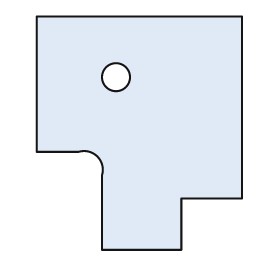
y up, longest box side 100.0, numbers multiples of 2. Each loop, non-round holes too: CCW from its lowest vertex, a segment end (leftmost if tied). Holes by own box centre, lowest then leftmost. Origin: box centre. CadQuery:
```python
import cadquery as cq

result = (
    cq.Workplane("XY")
    .moveTo(-16.0, -50.0)
    .lineTo(18.0, -50.0)
    .lineTo(18.0, -28.0)
    .lineTo(44.0, -28.0)
    .lineTo(44.0, 50.0)
    .lineTo(-44.0, 50.0)
    .lineTo(-44.0, -8.0)
    .lineTo(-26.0, -8.0)
    .threePointArc((-18.0, -10.0), (-16.0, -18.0))
    .close()
    .moveTo(-10.0, 24.0)
    .circle(6.0)
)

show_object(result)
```